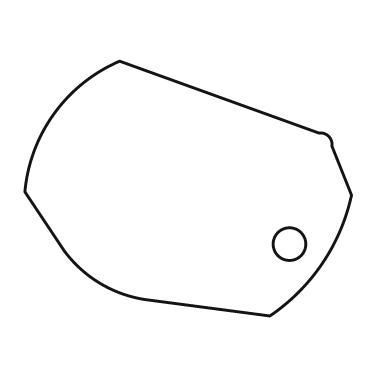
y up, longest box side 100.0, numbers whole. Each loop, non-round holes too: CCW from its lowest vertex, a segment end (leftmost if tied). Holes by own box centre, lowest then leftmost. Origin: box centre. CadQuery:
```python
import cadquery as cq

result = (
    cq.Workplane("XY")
    .moveTo(25.0, -39.0)
    .threePointArc((41.0, -23.0), (50.0, -2.0))
    .lineTo(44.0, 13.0)
    .threePointArc((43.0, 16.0), (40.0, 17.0))
    .lineTo(-21.0, 39.0)
    .threePointArc((-41.0, 23.0), (-50.0, -1.0))
    .lineTo(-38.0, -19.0)
    .threePointArc((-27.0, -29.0), (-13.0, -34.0))
    .close()
    .moveTo(31.0, -17.0)
    .circle(5.0)
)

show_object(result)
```